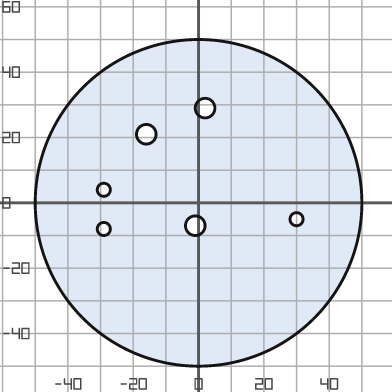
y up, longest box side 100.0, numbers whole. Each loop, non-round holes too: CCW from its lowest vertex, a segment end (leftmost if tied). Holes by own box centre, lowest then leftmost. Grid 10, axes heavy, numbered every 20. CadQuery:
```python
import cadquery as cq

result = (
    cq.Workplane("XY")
    .moveTo(0.0, 0.0)
    .circle(50.0)
    .moveTo(-29.0, -8.0)
    .circle(2.0)
    .moveTo(-1.0, -7.0)
    .circle(3.0)
    .moveTo(30.0, -5.0)
    .circle(2.0)
    .moveTo(-29.0, 4.0)
    .circle(2.0)
    .moveTo(-16.0, 21.0)
    .circle(3.0)
    .moveTo(2.0, 29.0)
    .circle(3.0)
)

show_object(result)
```